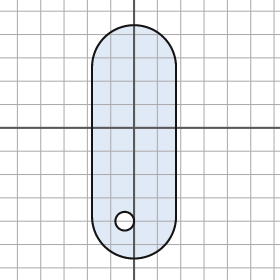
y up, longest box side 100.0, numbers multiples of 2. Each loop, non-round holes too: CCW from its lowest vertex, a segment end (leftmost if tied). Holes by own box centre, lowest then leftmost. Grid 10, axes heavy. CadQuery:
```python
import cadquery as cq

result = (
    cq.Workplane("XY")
    .moveTo(-18.0, -38.0)
    .threePointArc((0.0, -56.0), (18.0, -38.0))
    .lineTo(18.0, 26.0)
    .threePointArc((0.0, 44.0), (-18.0, 26.0))
    .close()
    .moveTo(-4.0, -40.0)
    .circle(4.0)
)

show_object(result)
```